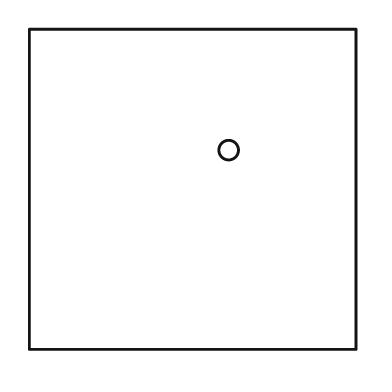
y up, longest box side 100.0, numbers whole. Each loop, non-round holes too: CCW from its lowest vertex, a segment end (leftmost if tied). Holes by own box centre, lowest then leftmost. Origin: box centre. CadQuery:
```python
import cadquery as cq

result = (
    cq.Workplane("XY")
    .moveTo(-50.0, -49.0)
    .lineTo(50.0, -49.0)
    .lineTo(50.0, 49.0)
    .lineTo(-50.0, 49.0)
    .close()
    .moveTo(11.0, 12.0)
    .circle(3.0)
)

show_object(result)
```